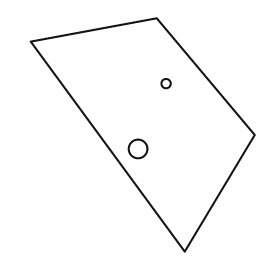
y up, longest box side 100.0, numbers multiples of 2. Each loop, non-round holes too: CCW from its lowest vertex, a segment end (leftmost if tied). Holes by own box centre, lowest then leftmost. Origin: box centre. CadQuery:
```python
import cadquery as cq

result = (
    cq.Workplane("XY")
    .moveTo(18.0, -50.0)
    .lineTo(48.0, 0.0)
    .lineTo(6.0, 50.0)
    .lineTo(-48.0, 40.0)
    .close()
    .moveTo(-2.0, -6.0)
    .circle(4.0)
    .moveTo(10.0, 22.0)
    .circle(2.0)
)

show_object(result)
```